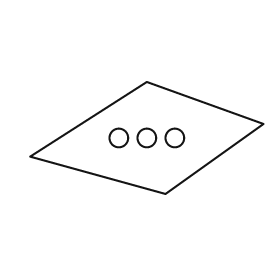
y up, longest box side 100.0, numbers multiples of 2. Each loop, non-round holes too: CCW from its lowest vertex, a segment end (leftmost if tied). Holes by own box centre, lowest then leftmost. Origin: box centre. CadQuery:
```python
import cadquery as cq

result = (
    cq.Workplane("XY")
    .moveTo(8.0, -24.0)
    .lineTo(50.0, 6.0)
    .lineTo(0.0, 24.0)
    .lineTo(-50.0, -8.0)
    .close()
    .moveTo(-12.0, 0.0)
    .circle(4.0)
    .moveTo(0.0, 0.0)
    .circle(4.0)
    .moveTo(12.0, 0.0)
    .circle(4.0)
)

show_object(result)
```